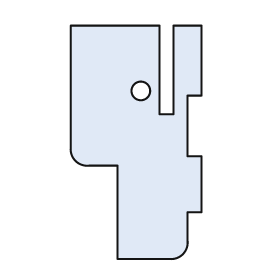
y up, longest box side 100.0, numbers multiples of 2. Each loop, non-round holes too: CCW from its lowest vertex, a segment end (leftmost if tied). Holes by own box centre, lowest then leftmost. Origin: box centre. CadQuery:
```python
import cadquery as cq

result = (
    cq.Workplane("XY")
    .moveTo(-8.0, -50.0)
    .lineTo(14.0, -50.0)
    .threePointArc((20.0, -48.0), (22.0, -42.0))
    .lineTo(22.0, -30.0)
    .lineTo(28.0, -30.0)
    .lineTo(28.0, -6.0)
    .lineTo(22.0, -6.0)
    .lineTo(22.0, 20.0)
    .lineTo(28.0, 20.0)
    .lineTo(28.0, 50.0)
    .lineTo(16.0, 50.0)
    .lineTo(16.0, 12.0)
    .lineTo(10.0, 12.0)
    .lineTo(10.0, 50.0)
    .lineTo(-28.0, 50.0)
    .lineTo(-28.0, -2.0)
    .threePointArc((-26.0, -8.0), (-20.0, -10.0))
    .lineTo(-8.0, -10.0)
    .close()
    .moveTo(2.0, 22.0)
    .circle(4.0)
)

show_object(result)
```